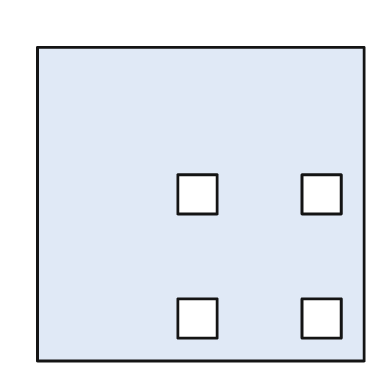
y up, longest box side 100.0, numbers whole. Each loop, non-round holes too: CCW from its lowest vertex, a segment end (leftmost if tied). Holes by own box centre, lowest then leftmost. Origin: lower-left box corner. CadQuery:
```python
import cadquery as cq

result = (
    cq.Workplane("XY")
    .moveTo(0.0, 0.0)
    .lineTo(100.0, 0.0)
    .lineTo(100.0, 96.0)
    .lineTo(0.0, 96.0)
    .close()
    .moveTo(43.0, 7.0)
    .lineTo(55.0, 7.0)
    .lineTo(55.0, 19.0)
    .lineTo(43.0, 19.0)
    .close()
    .moveTo(81.0, 7.0)
    .lineTo(93.0, 7.0)
    .lineTo(93.0, 19.0)
    .lineTo(81.0, 19.0)
    .close()
    .moveTo(43.0, 45.0)
    .lineTo(55.0, 45.0)
    .lineTo(55.0, 57.0)
    .lineTo(43.0, 57.0)
    .close()
    .moveTo(81.0, 45.0)
    .lineTo(93.0, 45.0)
    .lineTo(93.0, 57.0)
    .lineTo(81.0, 57.0)
    .close()
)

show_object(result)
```